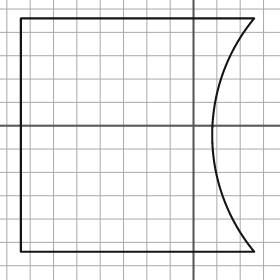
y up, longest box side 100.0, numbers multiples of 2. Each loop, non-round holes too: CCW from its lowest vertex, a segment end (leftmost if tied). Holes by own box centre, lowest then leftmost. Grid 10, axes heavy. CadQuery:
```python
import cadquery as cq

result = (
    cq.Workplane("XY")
    .moveTo(-74.0, -54.0)
    .lineTo(26.0, -54.0)
    .threePointArc((8.0, -4.0), (26.0, 46.0))
    .lineTo(-74.0, 46.0)
    .close()
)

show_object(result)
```